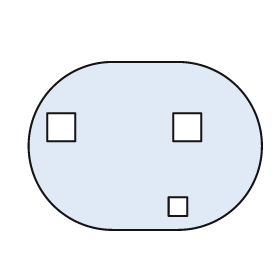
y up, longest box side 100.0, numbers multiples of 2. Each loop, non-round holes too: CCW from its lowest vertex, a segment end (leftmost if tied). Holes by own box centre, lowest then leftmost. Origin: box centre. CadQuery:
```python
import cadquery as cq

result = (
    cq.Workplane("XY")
    .moveTo(-14.0, -36.0)
    .lineTo(14.0, -36.0)
    .threePointArc((50.0, 0.0), (14.0, 36.0))
    .lineTo(-14.0, 36.0)
    .threePointArc((-50.0, 0.0), (-14.0, -36.0))
    .close()
    .moveTo(10.0, -30.0)
    .lineTo(18.0, -30.0)
    .lineTo(18.0, -22.0)
    .lineTo(10.0, -22.0)
    .close()
    .moveTo(-42.0, 2.0)
    .lineTo(-30.0, 2.0)
    .lineTo(-30.0, 14.0)
    .lineTo(-42.0, 14.0)
    .close()
    .moveTo(12.0, 2.0)
    .lineTo(24.0, 2.0)
    .lineTo(24.0, 14.0)
    .lineTo(12.0, 14.0)
    .close()
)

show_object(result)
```